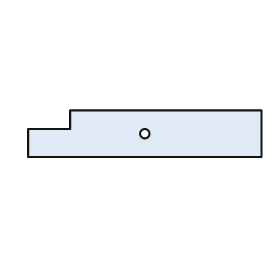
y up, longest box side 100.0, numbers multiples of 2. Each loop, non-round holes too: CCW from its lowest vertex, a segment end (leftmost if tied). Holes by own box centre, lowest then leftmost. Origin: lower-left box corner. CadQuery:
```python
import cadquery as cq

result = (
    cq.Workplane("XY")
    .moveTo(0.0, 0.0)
    .lineTo(100.0, 0.0)
    .lineTo(100.0, 20.0)
    .lineTo(18.0, 20.0)
    .lineTo(18.0, 12.0)
    .lineTo(0.0, 12.0)
    .close()
    .moveTo(50.0, 10.0)
    .circle(2.0)
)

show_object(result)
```